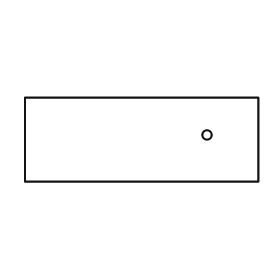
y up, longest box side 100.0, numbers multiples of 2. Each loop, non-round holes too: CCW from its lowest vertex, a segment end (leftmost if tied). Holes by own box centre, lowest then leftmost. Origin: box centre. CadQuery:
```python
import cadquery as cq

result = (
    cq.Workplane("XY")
    .moveTo(-50.0, -18.0)
    .lineTo(50.0, -18.0)
    .lineTo(50.0, 18.0)
    .lineTo(-50.0, 18.0)
    .close()
    .moveTo(28.0, 2.0)
    .circle(2.0)
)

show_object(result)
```